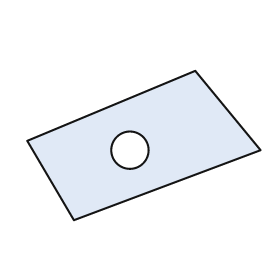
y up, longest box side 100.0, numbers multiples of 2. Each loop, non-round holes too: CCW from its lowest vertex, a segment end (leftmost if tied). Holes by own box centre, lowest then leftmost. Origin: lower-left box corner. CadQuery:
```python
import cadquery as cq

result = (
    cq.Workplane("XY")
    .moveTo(20.0, 0.0)
    .lineTo(100.0, 30.0)
    .lineTo(72.0, 64.0)
    .lineTo(0.0, 34.0)
    .close()
    .moveTo(44.0, 30.0)
    .circle(8.0)
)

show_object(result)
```